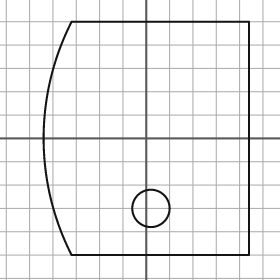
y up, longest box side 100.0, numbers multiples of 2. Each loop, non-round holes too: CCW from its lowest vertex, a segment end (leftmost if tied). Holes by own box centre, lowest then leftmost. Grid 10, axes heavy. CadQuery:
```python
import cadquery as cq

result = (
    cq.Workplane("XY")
    .moveTo(-32.0, -50.0)
    .lineTo(44.0, -50.0)
    .lineTo(44.0, 50.0)
    .lineTo(-32.0, 50.0)
    .threePointArc((-44.0, 0.0), (-32.0, -50.0))
    .close()
    .moveTo(2.0, -30.0)
    .circle(8.0)
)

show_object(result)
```